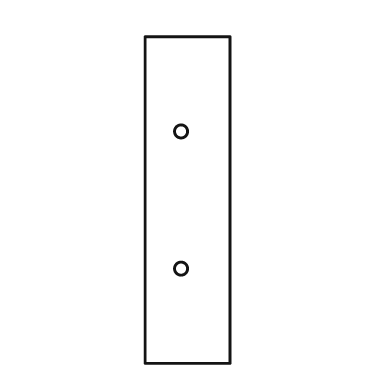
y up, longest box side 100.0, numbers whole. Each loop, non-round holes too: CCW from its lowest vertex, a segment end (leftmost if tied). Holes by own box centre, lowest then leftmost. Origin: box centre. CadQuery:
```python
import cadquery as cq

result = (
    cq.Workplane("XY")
    .moveTo(-13.0, -50.0)
    .lineTo(13.0, -50.0)
    .lineTo(13.0, 50.0)
    .lineTo(-13.0, 50.0)
    .close()
    .moveTo(-2.0, -21.0)
    .circle(2.0)
    .moveTo(-2.0, 21.0)
    .circle(2.0)
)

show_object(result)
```